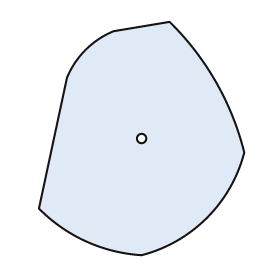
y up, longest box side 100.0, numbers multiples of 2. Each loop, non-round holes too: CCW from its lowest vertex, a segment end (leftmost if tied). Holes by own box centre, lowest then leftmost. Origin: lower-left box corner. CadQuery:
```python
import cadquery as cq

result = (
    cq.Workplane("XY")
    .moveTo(44.0, 0.0)
    .threePointArc((72.0, 16.0), (88.0, 44.0))
    .threePointArc((76.0, 74.0), (56.0, 100.0))
    .lineTo(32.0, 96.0)
    .threePointArc((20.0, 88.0), (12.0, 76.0))
    .lineTo(0.0, 20.0)
    .threePointArc((20.0, 6.0), (44.0, 0.0))
    .close()
    .moveTo(44.0, 50.0)
    .circle(2.0)
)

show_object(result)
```